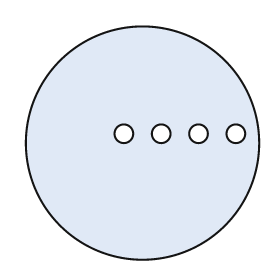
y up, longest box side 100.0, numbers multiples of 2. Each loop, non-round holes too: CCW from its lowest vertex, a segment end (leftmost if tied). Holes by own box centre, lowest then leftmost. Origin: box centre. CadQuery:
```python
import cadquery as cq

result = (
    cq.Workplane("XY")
    .moveTo(0.0, 0.0)
    .circle(50.0)
    .moveTo(-8.0, 4.0)
    .circle(4.0)
    .moveTo(8.0, 4.0)
    .circle(4.0)
    .moveTo(24.0, 4.0)
    .circle(4.0)
    .moveTo(40.0, 4.0)
    .circle(4.0)
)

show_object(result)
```